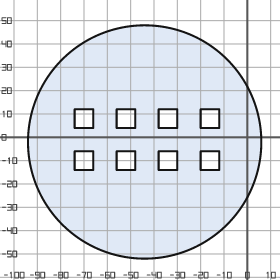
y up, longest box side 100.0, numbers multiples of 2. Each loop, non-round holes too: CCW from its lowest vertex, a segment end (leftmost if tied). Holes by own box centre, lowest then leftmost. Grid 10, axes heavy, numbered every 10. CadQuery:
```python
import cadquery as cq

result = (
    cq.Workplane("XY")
    .moveTo(-44.0, -2.0)
    .circle(50.0)
    .moveTo(-74.0, -14.0)
    .lineTo(-66.0, -14.0)
    .lineTo(-66.0, -6.0)
    .lineTo(-74.0, -6.0)
    .close()
    .moveTo(-56.0, -14.0)
    .lineTo(-48.0, -14.0)
    .lineTo(-48.0, -6.0)
    .lineTo(-56.0, -6.0)
    .close()
    .moveTo(-38.0, -14.0)
    .lineTo(-30.0, -14.0)
    .lineTo(-30.0, -6.0)
    .lineTo(-38.0, -6.0)
    .close()
    .moveTo(-20.0, -14.0)
    .lineTo(-12.0, -14.0)
    .lineTo(-12.0, -6.0)
    .lineTo(-20.0, -6.0)
    .close()
    .moveTo(-74.0, 4.0)
    .lineTo(-66.0, 4.0)
    .lineTo(-66.0, 12.0)
    .lineTo(-74.0, 12.0)
    .close()
    .moveTo(-56.0, 4.0)
    .lineTo(-48.0, 4.0)
    .lineTo(-48.0, 12.0)
    .lineTo(-56.0, 12.0)
    .close()
    .moveTo(-38.0, 4.0)
    .lineTo(-30.0, 4.0)
    .lineTo(-30.0, 12.0)
    .lineTo(-38.0, 12.0)
    .close()
    .moveTo(-20.0, 4.0)
    .lineTo(-12.0, 4.0)
    .lineTo(-12.0, 12.0)
    .lineTo(-20.0, 12.0)
    .close()
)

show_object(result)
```